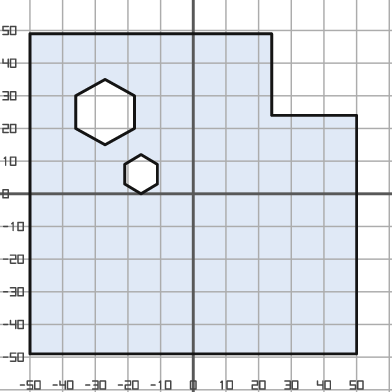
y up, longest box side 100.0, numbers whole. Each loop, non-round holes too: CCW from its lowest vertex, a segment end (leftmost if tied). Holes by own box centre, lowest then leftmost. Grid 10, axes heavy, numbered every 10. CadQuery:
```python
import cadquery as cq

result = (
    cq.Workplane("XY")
    .moveTo(-50.0, -49.0)
    .lineTo(50.0, -49.0)
    .lineTo(50.0, 24.0)
    .lineTo(24.0, 24.0)
    .lineTo(24.0, 49.0)
    .lineTo(-50.0, 49.0)
    .close()
    .moveTo(-16.0, 0.0)
    .lineTo(-11.0, 3.0)
    .lineTo(-11.0, 9.0)
    .lineTo(-16.0, 12.0)
    .lineTo(-21.0, 9.0)
    .lineTo(-21.0, 3.0)
    .close()
    .moveTo(-27.0, 15.0)
    .lineTo(-18.0, 20.0)
    .lineTo(-18.0, 30.0)
    .lineTo(-27.0, 35.0)
    .lineTo(-36.0, 30.0)
    .lineTo(-36.0, 20.0)
    .close()
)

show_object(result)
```